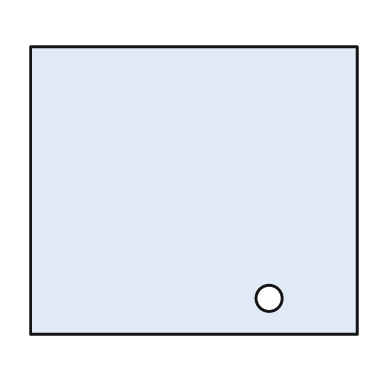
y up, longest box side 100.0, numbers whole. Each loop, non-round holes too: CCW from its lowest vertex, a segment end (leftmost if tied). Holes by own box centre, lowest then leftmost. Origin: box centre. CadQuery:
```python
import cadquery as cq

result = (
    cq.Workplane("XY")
    .moveTo(-50.0, -44.0)
    .lineTo(50.0, -44.0)
    .lineTo(50.0, 44.0)
    .lineTo(-50.0, 44.0)
    .close()
    .moveTo(23.0, -33.0)
    .circle(4.0)
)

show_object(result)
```